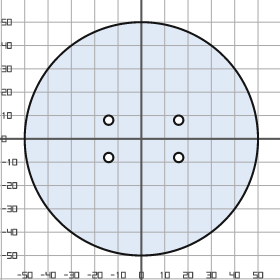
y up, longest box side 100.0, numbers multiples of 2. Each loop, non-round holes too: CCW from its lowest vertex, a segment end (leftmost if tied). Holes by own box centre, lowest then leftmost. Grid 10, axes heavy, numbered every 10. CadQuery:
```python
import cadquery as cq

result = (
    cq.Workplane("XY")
    .moveTo(0.0, 0.0)
    .circle(50.0)
    .moveTo(-14.0, -8.0)
    .circle(2.0)
    .moveTo(16.0, -8.0)
    .circle(2.0)
    .moveTo(-14.0, 8.0)
    .circle(2.0)
    .moveTo(16.0, 8.0)
    .circle(2.0)
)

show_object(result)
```